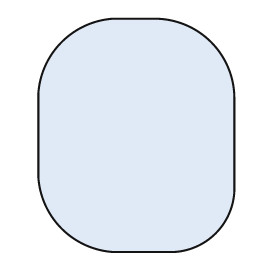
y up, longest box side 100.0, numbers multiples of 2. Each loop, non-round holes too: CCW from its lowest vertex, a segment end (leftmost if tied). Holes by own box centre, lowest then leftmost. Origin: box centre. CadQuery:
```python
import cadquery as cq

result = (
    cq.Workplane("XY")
    .moveTo(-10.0, -50.0)
    .lineTo(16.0, -50.0)
    .threePointArc((34.0, -42.0), (42.0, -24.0))
    .lineTo(42.0, 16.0)
    .threePointArc((32.0, 40.0), (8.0, 50.0))
    .lineTo(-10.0, 50.0)
    .threePointArc((-32.0, 40.0), (-42.0, 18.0))
    .lineTo(-42.0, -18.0)
    .threePointArc((-32.0, -40.0), (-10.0, -50.0))
    .close()
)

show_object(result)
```